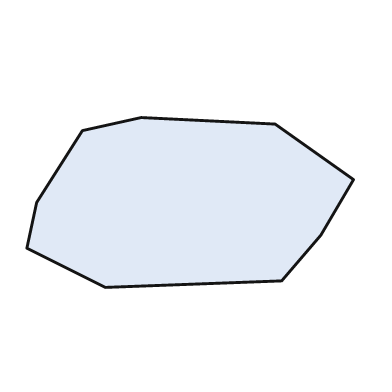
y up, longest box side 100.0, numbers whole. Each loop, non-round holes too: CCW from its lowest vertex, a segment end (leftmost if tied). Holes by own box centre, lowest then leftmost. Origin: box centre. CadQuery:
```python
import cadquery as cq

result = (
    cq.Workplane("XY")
    .moveTo(-26.0, -26.0)
    .lineTo(28.0, -24.0)
    .lineTo(40.0, -10.0)
    .lineTo(50.0, 7.0)
    .lineTo(26.0, 24.0)
    .lineTo(-15.0, 26.0)
    .lineTo(-33.0, 22.0)
    .lineTo(-47.0, 0.0)
    .lineTo(-50.0, -14.0)
    .close()
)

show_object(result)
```